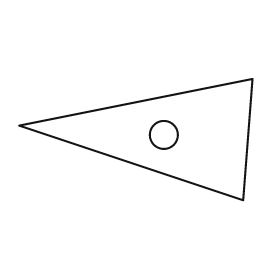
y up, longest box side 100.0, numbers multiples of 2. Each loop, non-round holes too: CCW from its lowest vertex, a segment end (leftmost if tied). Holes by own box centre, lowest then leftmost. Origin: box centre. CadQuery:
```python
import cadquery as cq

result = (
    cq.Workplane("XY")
    .moveTo(46.0, -26.0)
    .lineTo(50.0, 26.0)
    .lineTo(-50.0, 6.0)
    .close()
    .moveTo(12.0, 2.0)
    .circle(6.0)
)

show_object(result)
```